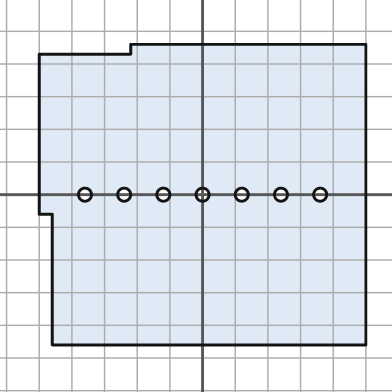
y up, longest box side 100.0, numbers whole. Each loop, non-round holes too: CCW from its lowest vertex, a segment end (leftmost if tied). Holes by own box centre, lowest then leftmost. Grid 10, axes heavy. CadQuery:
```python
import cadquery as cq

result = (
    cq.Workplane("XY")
    .moveTo(-46.0, -46.0)
    .lineTo(50.0, -46.0)
    .lineTo(50.0, 46.0)
    .lineTo(-22.0, 46.0)
    .lineTo(-22.0, 43.0)
    .lineTo(-50.0, 43.0)
    .lineTo(-50.0, -6.0)
    .lineTo(-46.0, -6.0)
    .close()
    .moveTo(-36.0, 0.0)
    .circle(2.0)
    .moveTo(-24.0, 0.0)
    .circle(2.0)
    .moveTo(-12.0, 0.0)
    .circle(2.0)
    .moveTo(0.0, 0.0)
    .circle(2.0)
    .moveTo(12.0, 0.0)
    .circle(2.0)
    .moveTo(24.0, 0.0)
    .circle(2.0)
    .moveTo(36.0, 0.0)
    .circle(2.0)
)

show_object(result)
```